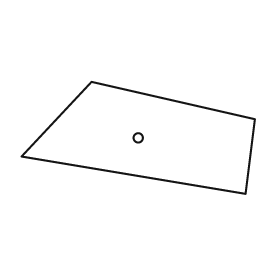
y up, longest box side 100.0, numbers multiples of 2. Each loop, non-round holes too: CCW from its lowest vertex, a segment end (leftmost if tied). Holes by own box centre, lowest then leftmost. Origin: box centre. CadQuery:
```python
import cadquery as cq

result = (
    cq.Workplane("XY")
    .moveTo(46.0, -24.0)
    .lineTo(50.0, 8.0)
    .lineTo(-20.0, 24.0)
    .lineTo(-50.0, -8.0)
    .close()
    .moveTo(0.0, 0.0)
    .circle(2.0)
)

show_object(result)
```